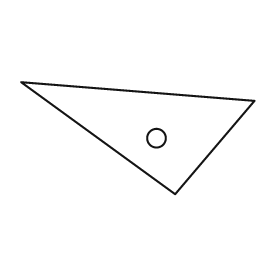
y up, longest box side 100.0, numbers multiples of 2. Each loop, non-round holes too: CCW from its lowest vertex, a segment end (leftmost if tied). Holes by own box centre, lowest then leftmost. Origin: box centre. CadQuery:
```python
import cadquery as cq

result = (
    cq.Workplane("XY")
    .moveTo(16.0, -24.0)
    .lineTo(50.0, 16.0)
    .lineTo(-50.0, 24.0)
    .close()
    .moveTo(8.0, 0.0)
    .circle(4.0)
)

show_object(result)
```